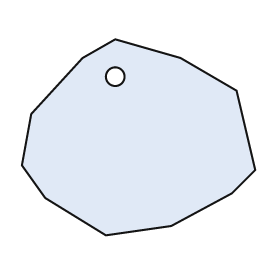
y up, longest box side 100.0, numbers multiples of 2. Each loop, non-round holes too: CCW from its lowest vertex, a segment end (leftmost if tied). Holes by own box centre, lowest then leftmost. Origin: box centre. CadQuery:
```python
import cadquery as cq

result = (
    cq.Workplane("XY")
    .moveTo(-14.0, -42.0)
    .lineTo(14.0, -38.0)
    .lineTo(40.0, -24.0)
    .lineTo(50.0, -14.0)
    .lineTo(42.0, 20.0)
    .lineTo(18.0, 34.0)
    .lineTo(-10.0, 42.0)
    .lineTo(-24.0, 34.0)
    .lineTo(-46.0, 10.0)
    .lineTo(-50.0, -12.0)
    .lineTo(-40.0, -26.0)
    .close()
    .moveTo(-10.0, 26.0)
    .circle(4.0)
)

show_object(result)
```